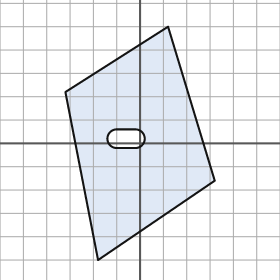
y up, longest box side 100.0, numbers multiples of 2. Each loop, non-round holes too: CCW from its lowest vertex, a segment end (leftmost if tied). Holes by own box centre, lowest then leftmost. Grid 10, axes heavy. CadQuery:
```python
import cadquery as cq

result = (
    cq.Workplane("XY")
    .moveTo(-18.0, -50.0)
    .lineTo(32.0, -16.0)
    .lineTo(12.0, 50.0)
    .lineTo(-32.0, 22.0)
    .close()
    .moveTo(-10.0, -2.0)
    .lineTo(-2.0, -2.0)
    .threePointArc((2.0, 2.0), (-2.0, 6.0))
    .lineTo(-10.0, 6.0)
    .threePointArc((-14.0, 2.0), (-10.0, -2.0))
    .close()
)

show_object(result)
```